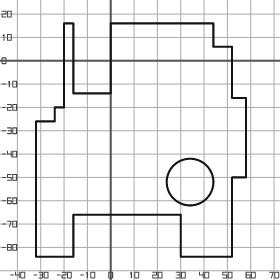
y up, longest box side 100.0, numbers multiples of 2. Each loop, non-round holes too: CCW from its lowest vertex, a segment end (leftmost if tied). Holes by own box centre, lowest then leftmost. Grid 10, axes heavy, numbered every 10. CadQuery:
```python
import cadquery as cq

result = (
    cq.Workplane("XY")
    .moveTo(-32.0, -84.0)
    .lineTo(-16.0, -84.0)
    .lineTo(-16.0, -66.0)
    .lineTo(30.0, -66.0)
    .lineTo(30.0, -84.0)
    .lineTo(52.0, -84.0)
    .lineTo(52.0, -50.0)
    .lineTo(58.0, -50.0)
    .lineTo(58.0, -16.0)
    .lineTo(52.0, -16.0)
    .lineTo(52.0, 6.0)
    .lineTo(44.0, 6.0)
    .lineTo(44.0, 16.0)
    .lineTo(0.0, 16.0)
    .lineTo(0.0, -14.0)
    .lineTo(-16.0, -14.0)
    .lineTo(-16.0, 16.0)
    .lineTo(-20.0, 16.0)
    .lineTo(-20.0, -20.0)
    .lineTo(-24.0, -20.0)
    .lineTo(-24.0, -26.0)
    .lineTo(-32.0, -26.0)
    .close()
    .moveTo(34.0, -52.0)
    .circle(10.0)
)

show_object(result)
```